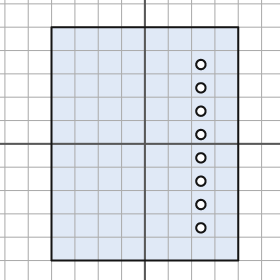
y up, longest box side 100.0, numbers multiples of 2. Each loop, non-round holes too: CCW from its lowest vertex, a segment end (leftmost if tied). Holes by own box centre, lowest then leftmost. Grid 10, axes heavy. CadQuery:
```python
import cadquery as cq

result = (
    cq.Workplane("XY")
    .moveTo(-40.0, -50.0)
    .lineTo(40.0, -50.0)
    .lineTo(40.0, 50.0)
    .lineTo(-40.0, 50.0)
    .close()
    .moveTo(24.0, -36.0)
    .circle(2.0)
    .moveTo(24.0, -26.0)
    .circle(2.0)
    .moveTo(24.0, -16.0)
    .circle(2.0)
    .moveTo(24.0, -6.0)
    .circle(2.0)
    .moveTo(24.0, 4.0)
    .circle(2.0)
    .moveTo(24.0, 14.0)
    .circle(2.0)
    .moveTo(24.0, 24.0)
    .circle(2.0)
    .moveTo(24.0, 34.0)
    .circle(2.0)
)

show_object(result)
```